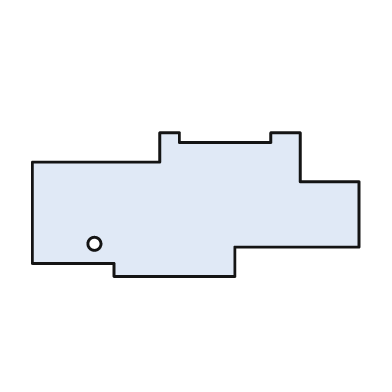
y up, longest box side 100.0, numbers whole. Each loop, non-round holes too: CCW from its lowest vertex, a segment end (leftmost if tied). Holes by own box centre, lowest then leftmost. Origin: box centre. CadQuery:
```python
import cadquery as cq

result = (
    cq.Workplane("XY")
    .moveTo(-25.0, -22.0)
    .lineTo(12.0, -22.0)
    .lineTo(12.0, -13.0)
    .lineTo(50.0, -13.0)
    .lineTo(50.0, 7.0)
    .lineTo(32.0, 7.0)
    .lineTo(32.0, 22.0)
    .lineTo(23.0, 22.0)
    .lineTo(23.0, 19.0)
    .lineTo(-5.0, 19.0)
    .lineTo(-5.0, 22.0)
    .lineTo(-11.0, 22.0)
    .lineTo(-11.0, 13.0)
    .lineTo(-50.0, 13.0)
    .lineTo(-50.0, -18.0)
    .lineTo(-25.0, -18.0)
    .close()
    .moveTo(-31.0, -12.0)
    .circle(2.0)
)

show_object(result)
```